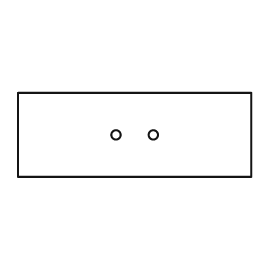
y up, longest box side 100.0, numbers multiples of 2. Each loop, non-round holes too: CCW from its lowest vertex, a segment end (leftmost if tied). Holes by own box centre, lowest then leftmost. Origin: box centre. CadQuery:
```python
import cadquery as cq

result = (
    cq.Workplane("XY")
    .moveTo(-50.0, -18.0)
    .lineTo(50.0, -18.0)
    .lineTo(50.0, 18.0)
    .lineTo(-50.0, 18.0)
    .close()
    .moveTo(-8.0, 0.0)
    .circle(2.0)
    .moveTo(8.0, 0.0)
    .circle(2.0)
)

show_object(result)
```